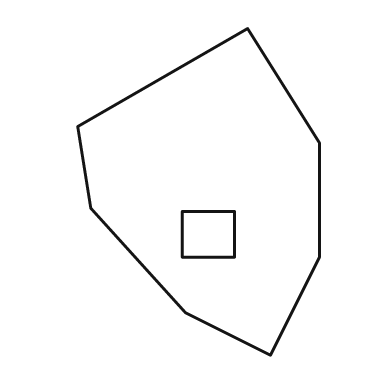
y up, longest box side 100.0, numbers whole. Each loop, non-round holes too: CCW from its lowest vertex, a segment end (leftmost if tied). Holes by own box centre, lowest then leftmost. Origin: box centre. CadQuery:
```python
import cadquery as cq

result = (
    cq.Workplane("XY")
    .moveTo(22.0, -50.0)
    .lineTo(37.0, -20.0)
    .lineTo(37.0, 15.0)
    .lineTo(15.0, 50.0)
    .lineTo(-37.0, 20.0)
    .lineTo(-33.0, -5.0)
    .lineTo(-4.0, -37.0)
    .close()
    .moveTo(-5.0, -20.0)
    .lineTo(11.0, -20.0)
    .lineTo(11.0, -6.0)
    .lineTo(-5.0, -6.0)
    .close()
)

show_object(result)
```